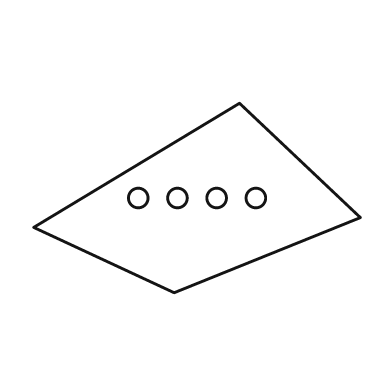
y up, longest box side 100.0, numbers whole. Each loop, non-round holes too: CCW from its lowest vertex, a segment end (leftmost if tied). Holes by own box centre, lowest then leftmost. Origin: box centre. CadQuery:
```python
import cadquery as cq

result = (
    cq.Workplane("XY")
    .moveTo(-7.0, -29.0)
    .lineTo(50.0, -6.0)
    .lineTo(13.0, 29.0)
    .lineTo(-50.0, -9.0)
    .close()
    .moveTo(-18.0, 0.0)
    .circle(3.0)
    .moveTo(-6.0, 0.0)
    .circle(3.0)
    .moveTo(6.0, 0.0)
    .circle(3.0)
    .moveTo(18.0, 0.0)
    .circle(3.0)
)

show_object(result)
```